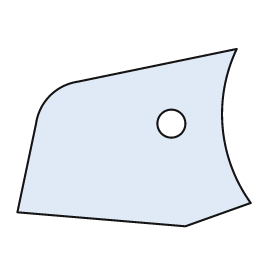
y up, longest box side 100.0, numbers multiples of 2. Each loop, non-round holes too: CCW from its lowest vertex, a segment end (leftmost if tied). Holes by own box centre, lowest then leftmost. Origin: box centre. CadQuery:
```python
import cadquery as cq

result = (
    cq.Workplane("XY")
    .moveTo(22.0, -38.0)
    .lineTo(50.0, -28.0)
    .threePointArc((38.0, 4.0), (44.0, 38.0))
    .lineTo(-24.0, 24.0)
    .threePointArc((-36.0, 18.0), (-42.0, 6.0))
    .lineTo(-50.0, -32.0)
    .close()
    .moveTo(16.0, 6.0)
    .circle(6.0)
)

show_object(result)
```